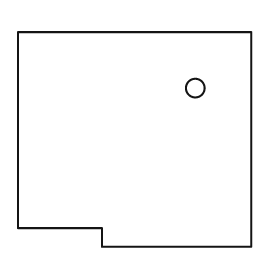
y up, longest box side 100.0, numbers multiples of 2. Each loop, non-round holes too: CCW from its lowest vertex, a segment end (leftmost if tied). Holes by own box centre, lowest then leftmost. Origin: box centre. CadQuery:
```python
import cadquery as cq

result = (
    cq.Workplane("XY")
    .moveTo(-14.0, -46.0)
    .lineTo(50.0, -46.0)
    .lineTo(50.0, 46.0)
    .lineTo(-50.0, 46.0)
    .lineTo(-50.0, -38.0)
    .lineTo(-14.0, -38.0)
    .close()
    .moveTo(26.0, 22.0)
    .circle(4.0)
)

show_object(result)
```